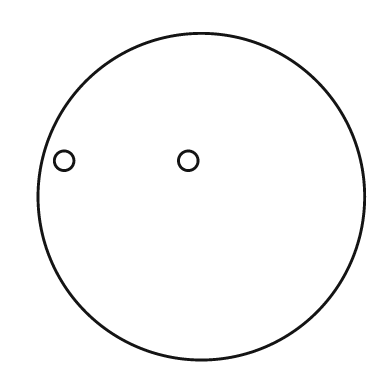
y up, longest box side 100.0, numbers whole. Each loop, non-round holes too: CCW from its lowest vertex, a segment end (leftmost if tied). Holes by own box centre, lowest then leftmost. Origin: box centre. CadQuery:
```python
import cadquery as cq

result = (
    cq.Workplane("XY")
    .moveTo(0.0, 0.0)
    .circle(50.0)
    .moveTo(-42.0, 11.0)
    .circle(3.0)
    .moveTo(-4.0, 11.0)
    .circle(3.0)
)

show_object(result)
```